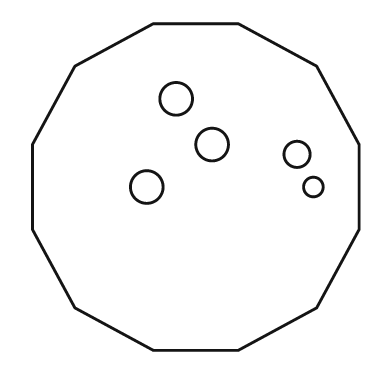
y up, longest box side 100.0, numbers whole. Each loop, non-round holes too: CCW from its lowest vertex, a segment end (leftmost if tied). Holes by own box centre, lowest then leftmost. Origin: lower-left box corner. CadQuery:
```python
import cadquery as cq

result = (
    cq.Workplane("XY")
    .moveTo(37.0, 0.0)
    .lineTo(63.0, 0.0)
    .lineTo(87.0, 13.0)
    .lineTo(100.0, 37.0)
    .lineTo(100.0, 63.0)
    .lineTo(87.0, 87.0)
    .lineTo(63.0, 100.0)
    .lineTo(37.0, 100.0)
    .lineTo(13.0, 87.0)
    .lineTo(0.0, 63.0)
    .lineTo(0.0, 37.0)
    .lineTo(13.0, 13.0)
    .close()
    .moveTo(35.0, 50.0)
    .circle(5.0)
    .moveTo(86.0, 50.0)
    .circle(3.0)
    .moveTo(81.0, 60.0)
    .circle(4.0)
    .moveTo(55.0, 63.0)
    .circle(5.0)
    .moveTo(44.0, 77.0)
    .circle(5.0)
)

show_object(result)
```